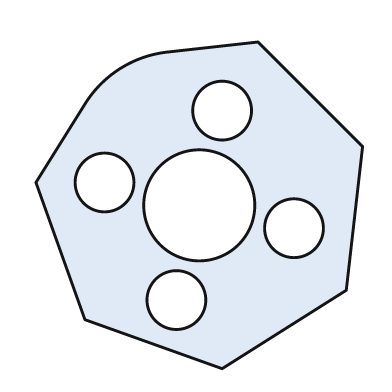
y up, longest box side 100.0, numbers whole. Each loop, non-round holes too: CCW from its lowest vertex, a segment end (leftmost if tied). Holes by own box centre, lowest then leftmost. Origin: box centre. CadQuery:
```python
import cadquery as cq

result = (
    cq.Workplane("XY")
    .moveTo(7.0, -50.0)
    .lineTo(45.0, -26.0)
    .lineTo(50.0, 18.0)
    .lineTo(18.0, 50.0)
    .lineTo(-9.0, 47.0)
    .threePointArc((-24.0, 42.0), (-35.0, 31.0))
    .lineTo(-50.0, 7.0)
    .lineTo(-35.0, -35.0)
    .close()
    .moveTo(-7.0, -29.0)
    .circle(9.0)
    .moveTo(29.0, -7.0)
    .circle(9.0)
    .moveTo(0.0, 0.0)
    .circle(17.0)
    .moveTo(-29.0, 7.0)
    .circle(9.0)
    .moveTo(7.0, 29.0)
    .circle(9.0)
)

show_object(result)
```